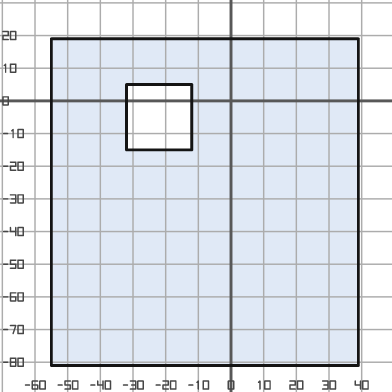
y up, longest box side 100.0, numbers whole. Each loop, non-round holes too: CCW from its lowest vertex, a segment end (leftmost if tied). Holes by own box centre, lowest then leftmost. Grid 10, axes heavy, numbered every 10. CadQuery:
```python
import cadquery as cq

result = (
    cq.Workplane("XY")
    .moveTo(-55.0, -81.0)
    .lineTo(39.0, -81.0)
    .lineTo(39.0, 19.0)
    .lineTo(-55.0, 19.0)
    .close()
    .moveTo(-32.0, -15.0)
    .lineTo(-12.0, -15.0)
    .lineTo(-12.0, 5.0)
    .lineTo(-32.0, 5.0)
    .close()
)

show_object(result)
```